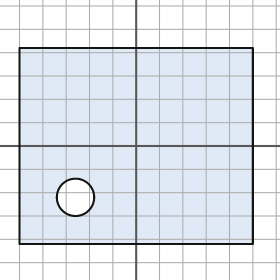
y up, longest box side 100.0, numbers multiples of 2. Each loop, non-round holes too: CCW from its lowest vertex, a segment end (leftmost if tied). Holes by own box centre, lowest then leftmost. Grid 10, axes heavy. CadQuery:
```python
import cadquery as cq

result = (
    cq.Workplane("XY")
    .moveTo(-50.0, -42.0)
    .lineTo(50.0, -42.0)
    .lineTo(50.0, 42.0)
    .lineTo(-50.0, 42.0)
    .close()
    .moveTo(-26.0, -22.0)
    .circle(8.0)
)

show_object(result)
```